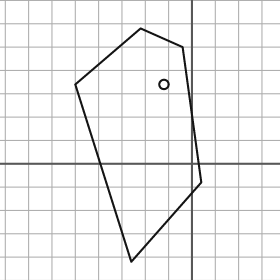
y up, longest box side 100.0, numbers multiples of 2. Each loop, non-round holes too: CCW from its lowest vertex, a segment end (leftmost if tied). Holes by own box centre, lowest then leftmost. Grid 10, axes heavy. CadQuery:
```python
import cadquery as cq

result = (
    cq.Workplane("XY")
    .moveTo(-26.0, -42.0)
    .lineTo(4.0, -8.0)
    .lineTo(-4.0, 50.0)
    .lineTo(-22.0, 58.0)
    .lineTo(-50.0, 34.0)
    .close()
    .moveTo(-12.0, 34.0)
    .circle(2.0)
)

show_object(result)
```